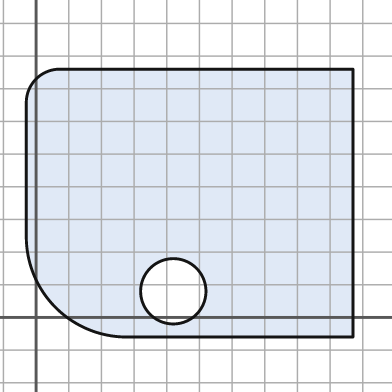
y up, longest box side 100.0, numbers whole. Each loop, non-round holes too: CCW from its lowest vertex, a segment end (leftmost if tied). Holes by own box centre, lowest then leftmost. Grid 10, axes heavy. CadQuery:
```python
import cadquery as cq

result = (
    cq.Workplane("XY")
    .moveTo(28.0, -6.0)
    .lineTo(97.0, -6.0)
    .lineTo(97.0, 76.0)
    .lineTo(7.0, 76.0)
    .threePointArc((0.0, 73.0), (-3.0, 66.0))
    .lineTo(-3.0, 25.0)
    .threePointArc((6.0, 3.0), (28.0, -6.0))
    .close()
    .moveTo(42.0, 8.0)
    .circle(10.0)
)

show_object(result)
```